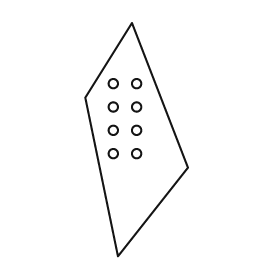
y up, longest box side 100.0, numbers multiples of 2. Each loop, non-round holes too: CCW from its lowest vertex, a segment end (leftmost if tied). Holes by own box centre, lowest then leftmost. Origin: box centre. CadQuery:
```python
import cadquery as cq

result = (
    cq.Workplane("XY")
    .moveTo(-8.0, -50.0)
    .lineTo(22.0, -12.0)
    .lineTo(-2.0, 50.0)
    .lineTo(-22.0, 18.0)
    .close()
    .moveTo(-10.0, -6.0)
    .circle(2.0)
    .moveTo(0.0, -6.0)
    .circle(2.0)
    .moveTo(-10.0, 4.0)
    .circle(2.0)
    .moveTo(0.0, 4.0)
    .circle(2.0)
    .moveTo(-10.0, 14.0)
    .circle(2.0)
    .moveTo(0.0, 14.0)
    .circle(2.0)
    .moveTo(-10.0, 24.0)
    .circle(2.0)
    .moveTo(0.0, 24.0)
    .circle(2.0)
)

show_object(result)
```